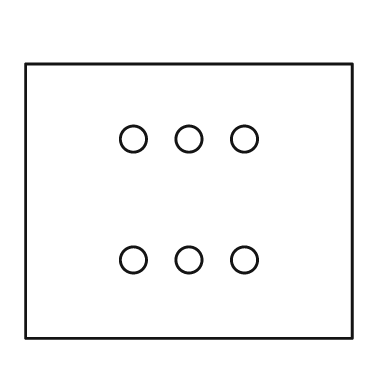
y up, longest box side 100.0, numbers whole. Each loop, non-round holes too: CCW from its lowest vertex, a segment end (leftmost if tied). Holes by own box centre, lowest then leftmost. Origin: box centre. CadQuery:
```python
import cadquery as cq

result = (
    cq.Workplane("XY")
    .moveTo(-50.0, -42.0)
    .lineTo(50.0, -42.0)
    .lineTo(50.0, 42.0)
    .lineTo(-50.0, 42.0)
    .close()
    .moveTo(-17.0, -18.0)
    .circle(4.0)
    .moveTo(0.0, -18.0)
    .circle(4.0)
    .moveTo(17.0, -18.0)
    .circle(4.0)
    .moveTo(-17.0, 19.0)
    .circle(4.0)
    .moveTo(0.0, 19.0)
    .circle(4.0)
    .moveTo(17.0, 19.0)
    .circle(4.0)
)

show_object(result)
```